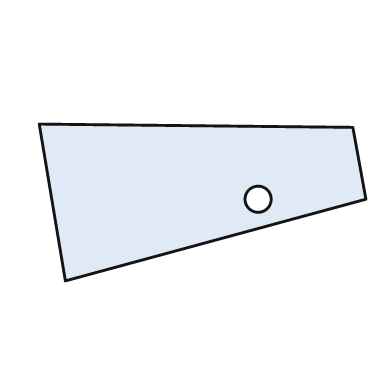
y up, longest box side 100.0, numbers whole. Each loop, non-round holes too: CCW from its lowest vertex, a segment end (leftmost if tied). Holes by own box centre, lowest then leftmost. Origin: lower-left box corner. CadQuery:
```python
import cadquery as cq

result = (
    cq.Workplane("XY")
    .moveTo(8.0, 0.0)
    .lineTo(100.0, 25.0)
    .lineTo(96.0, 47.0)
    .lineTo(0.0, 48.0)
    .close()
    .moveTo(67.0, 25.0)
    .circle(4.0)
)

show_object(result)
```